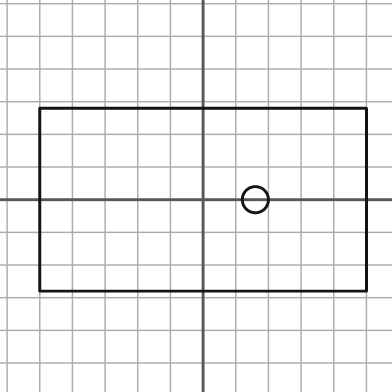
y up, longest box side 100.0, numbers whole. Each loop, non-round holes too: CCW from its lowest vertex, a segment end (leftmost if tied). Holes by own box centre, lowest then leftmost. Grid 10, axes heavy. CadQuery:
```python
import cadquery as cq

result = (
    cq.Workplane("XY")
    .moveTo(-50.0, -28.0)
    .lineTo(50.0, -28.0)
    .lineTo(50.0, 28.0)
    .lineTo(-50.0, 28.0)
    .close()
    .moveTo(16.0, 0.0)
    .circle(4.0)
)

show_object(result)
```